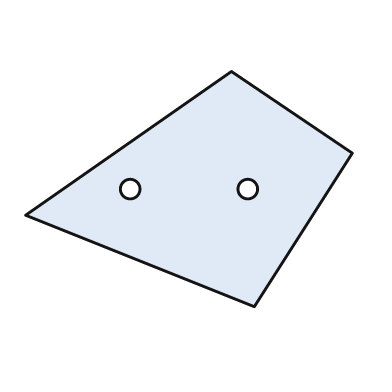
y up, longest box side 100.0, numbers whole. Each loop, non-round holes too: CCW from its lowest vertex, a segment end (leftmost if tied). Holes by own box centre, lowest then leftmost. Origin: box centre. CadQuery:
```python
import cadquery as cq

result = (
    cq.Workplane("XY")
    .moveTo(20.0, -36.0)
    .lineTo(50.0, 11.0)
    .lineTo(13.0, 36.0)
    .lineTo(-50.0, -8.0)
    .close()
    .moveTo(-18.0, 0.0)
    .circle(3.0)
    .moveTo(18.0, 0.0)
    .circle(3.0)
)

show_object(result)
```